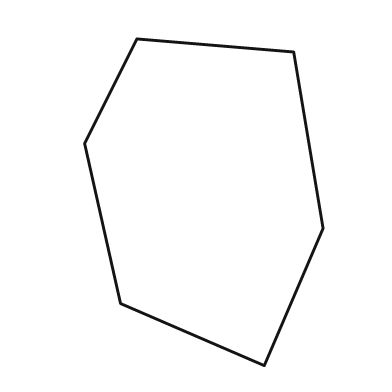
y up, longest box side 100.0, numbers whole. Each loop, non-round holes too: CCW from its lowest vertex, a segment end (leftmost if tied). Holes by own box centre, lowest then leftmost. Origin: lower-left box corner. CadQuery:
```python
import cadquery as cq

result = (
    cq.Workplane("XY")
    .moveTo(55.0, 0.0)
    .lineTo(73.0, 42.0)
    .lineTo(64.0, 96.0)
    .lineTo(16.0, 100.0)
    .lineTo(0.0, 68.0)
    .lineTo(11.0, 19.0)
    .close()
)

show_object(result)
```